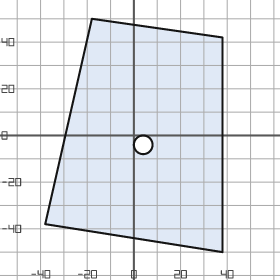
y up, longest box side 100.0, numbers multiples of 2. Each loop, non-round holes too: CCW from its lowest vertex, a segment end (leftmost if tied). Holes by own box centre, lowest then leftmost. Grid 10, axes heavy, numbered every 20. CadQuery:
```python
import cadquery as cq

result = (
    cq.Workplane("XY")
    .moveTo(38.0, -50.0)
    .lineTo(38.0, 42.0)
    .lineTo(-18.0, 50.0)
    .lineTo(-38.0, -38.0)
    .close()
    .moveTo(4.0, -4.0)
    .circle(4.0)
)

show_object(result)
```